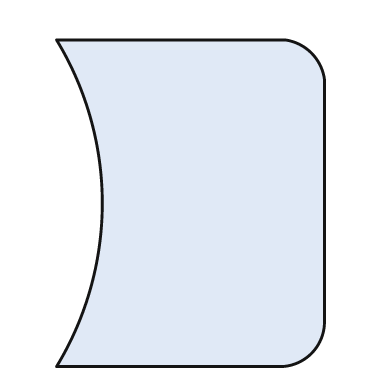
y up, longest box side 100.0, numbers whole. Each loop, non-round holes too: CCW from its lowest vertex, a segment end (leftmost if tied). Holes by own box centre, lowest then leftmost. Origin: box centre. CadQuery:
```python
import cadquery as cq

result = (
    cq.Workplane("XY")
    .moveTo(-41.0, -50.0)
    .lineTo(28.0, -50.0)
    .threePointArc((37.0, -46.0), (41.0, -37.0))
    .lineTo(41.0, 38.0)
    .threePointArc((37.0, 46.0), (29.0, 50.0))
    .lineTo(-41.0, 50.0)
    .threePointArc((-27.0, 0.0), (-41.0, -50.0))
    .close()
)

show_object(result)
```